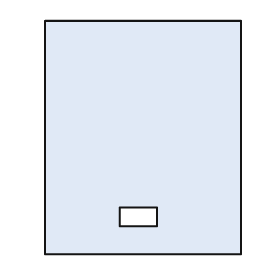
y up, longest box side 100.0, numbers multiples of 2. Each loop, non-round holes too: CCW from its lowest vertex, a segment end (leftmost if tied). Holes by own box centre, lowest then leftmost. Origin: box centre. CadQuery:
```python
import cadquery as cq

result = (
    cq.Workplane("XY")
    .moveTo(-42.0, -50.0)
    .lineTo(42.0, -50.0)
    .lineTo(42.0, 50.0)
    .lineTo(-42.0, 50.0)
    .close()
    .moveTo(-10.0, -38.0)
    .lineTo(6.0, -38.0)
    .lineTo(6.0, -30.0)
    .lineTo(-10.0, -30.0)
    .close()
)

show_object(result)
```